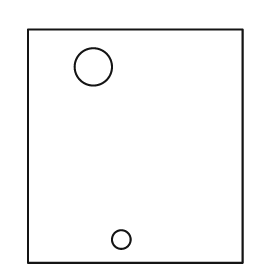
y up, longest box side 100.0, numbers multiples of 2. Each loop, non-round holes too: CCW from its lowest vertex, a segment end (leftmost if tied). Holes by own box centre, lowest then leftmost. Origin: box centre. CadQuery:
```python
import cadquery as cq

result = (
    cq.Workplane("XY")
    .moveTo(-46.0, -50.0)
    .lineTo(46.0, -50.0)
    .lineTo(46.0, 50.0)
    .lineTo(-46.0, 50.0)
    .close()
    .moveTo(-6.0, -40.0)
    .circle(4.0)
    .moveTo(-18.0, 34.0)
    .circle(8.0)
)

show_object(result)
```